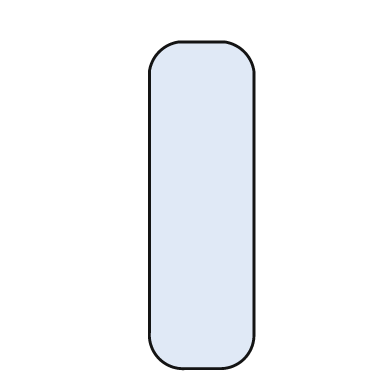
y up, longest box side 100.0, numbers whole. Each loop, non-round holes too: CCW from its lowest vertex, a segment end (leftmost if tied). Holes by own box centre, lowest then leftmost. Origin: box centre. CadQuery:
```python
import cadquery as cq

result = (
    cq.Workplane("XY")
    .moveTo(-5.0, -50.0)
    .lineTo(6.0, -50.0)
    .threePointArc((13.0, -47.0), (16.0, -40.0))
    .lineTo(16.0, 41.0)
    .threePointArc((13.0, 47.0), (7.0, 50.0))
    .lineTo(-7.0, 50.0)
    .threePointArc((-13.0, 47.0), (-16.0, 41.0))
    .lineTo(-16.0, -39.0)
    .threePointArc((-13.0, -47.0), (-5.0, -50.0))
    .close()
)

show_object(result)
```